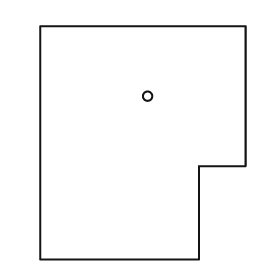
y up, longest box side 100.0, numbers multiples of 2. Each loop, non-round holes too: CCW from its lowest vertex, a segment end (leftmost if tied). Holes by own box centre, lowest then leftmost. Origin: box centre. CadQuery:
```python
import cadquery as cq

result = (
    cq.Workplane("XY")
    .moveTo(-44.0, -50.0)
    .lineTo(24.0, -50.0)
    .lineTo(24.0, -10.0)
    .lineTo(44.0, -10.0)
    .lineTo(44.0, 50.0)
    .lineTo(-44.0, 50.0)
    .close()
    .moveTo(2.0, 20.0)
    .circle(2.0)
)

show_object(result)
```